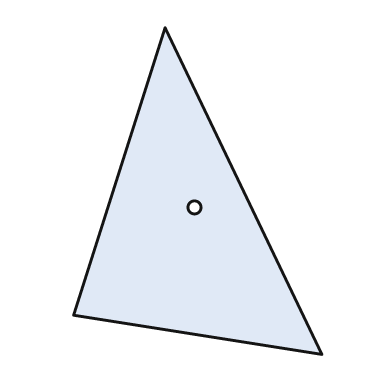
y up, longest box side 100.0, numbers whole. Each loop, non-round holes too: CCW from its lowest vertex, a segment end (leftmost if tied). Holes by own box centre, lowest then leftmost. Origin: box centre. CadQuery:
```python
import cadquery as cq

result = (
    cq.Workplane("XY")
    .moveTo(38.0, -50.0)
    .lineTo(-10.0, 50.0)
    .lineTo(-38.0, -38.0)
    .close()
    .moveTo(-1.0, -5.0)
    .circle(2.0)
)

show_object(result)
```